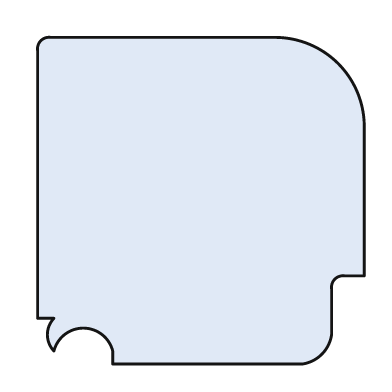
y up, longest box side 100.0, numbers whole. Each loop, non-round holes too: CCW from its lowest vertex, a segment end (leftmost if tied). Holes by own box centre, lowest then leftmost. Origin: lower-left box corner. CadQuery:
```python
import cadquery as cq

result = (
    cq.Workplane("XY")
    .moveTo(23.0, 0.0)
    .lineTo(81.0, 0.0)
    .threePointArc((87.0, 3.0), (90.0, 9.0))
    .lineTo(90.0, 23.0)
    .threePointArc((91.0, 26.0), (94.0, 27.0))
    .lineTo(100.0, 27.0)
    .lineTo(100.0, 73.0)
    .threePointArc((92.0, 92.0), (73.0, 100.0))
    .lineTo(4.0, 100.0)
    .threePointArc((1.0, 99.0), (0.0, 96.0))
    .lineTo(0.0, 14.0)
    .lineTo(5.0, 14.0)
    .threePointArc((3.0, 9.0), (5.0, 4.0))
    .threePointArc((14.0, 11.0), (23.0, 4.0))
    .close()
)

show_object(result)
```